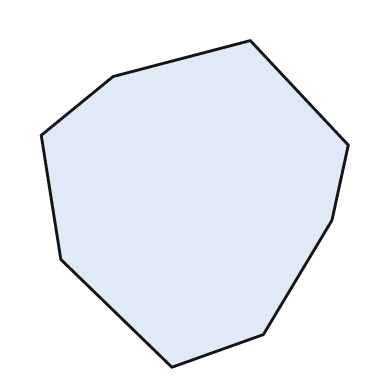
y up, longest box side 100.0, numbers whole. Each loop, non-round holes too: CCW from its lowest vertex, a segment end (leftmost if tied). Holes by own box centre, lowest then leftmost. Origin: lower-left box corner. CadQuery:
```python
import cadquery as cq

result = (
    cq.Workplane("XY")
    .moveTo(40.0, 0.0)
    .lineTo(68.0, 10.0)
    .lineTo(89.0, 45.0)
    .lineTo(94.0, 68.0)
    .lineTo(64.0, 100.0)
    .lineTo(22.0, 89.0)
    .lineTo(0.0, 71.0)
    .lineTo(6.0, 33.0)
    .close()
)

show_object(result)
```